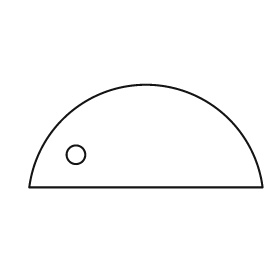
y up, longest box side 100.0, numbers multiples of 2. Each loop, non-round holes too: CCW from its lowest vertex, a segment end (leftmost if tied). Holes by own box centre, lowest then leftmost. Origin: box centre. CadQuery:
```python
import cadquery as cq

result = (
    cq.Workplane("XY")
    .moveTo(-50.0, -22.0)
    .lineTo(50.0, -22.0)
    .threePointArc((0.0, 22.0), (-50.0, -22.0))
    .close()
    .moveTo(-30.0, -8.0)
    .circle(4.0)
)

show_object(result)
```